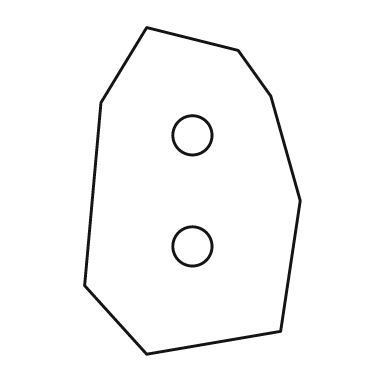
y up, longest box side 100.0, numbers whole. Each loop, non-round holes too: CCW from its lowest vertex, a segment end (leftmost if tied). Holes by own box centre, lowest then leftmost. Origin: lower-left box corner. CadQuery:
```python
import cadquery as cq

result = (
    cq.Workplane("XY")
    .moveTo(19.0, 0.0)
    .lineTo(60.0, 7.0)
    .lineTo(66.0, 47.0)
    .lineTo(57.0, 79.0)
    .lineTo(47.0, 93.0)
    .lineTo(19.0, 100.0)
    .lineTo(5.0, 77.0)
    .lineTo(0.0, 21.0)
    .close()
    .moveTo(33.0, 33.0)
    .circle(6.0)
    .moveTo(33.0, 67.0)
    .circle(6.0)
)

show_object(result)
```